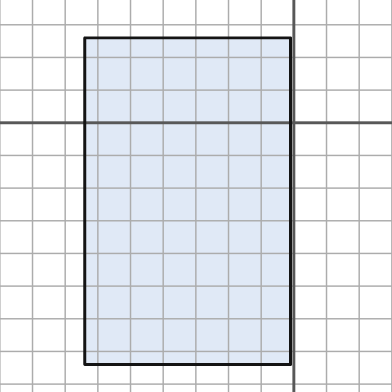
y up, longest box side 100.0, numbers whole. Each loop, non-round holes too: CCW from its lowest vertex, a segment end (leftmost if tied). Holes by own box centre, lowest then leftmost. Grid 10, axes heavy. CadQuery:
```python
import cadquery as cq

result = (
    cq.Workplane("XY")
    .moveTo(-64.0, -74.0)
    .lineTo(-1.0, -74.0)
    .lineTo(-1.0, 26.0)
    .lineTo(-64.0, 26.0)
    .close()
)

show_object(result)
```